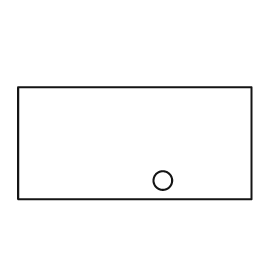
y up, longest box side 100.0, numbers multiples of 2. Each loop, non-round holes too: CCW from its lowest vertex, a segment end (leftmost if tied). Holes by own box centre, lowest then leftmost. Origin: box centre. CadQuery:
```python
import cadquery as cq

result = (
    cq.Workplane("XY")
    .moveTo(-50.0, -24.0)
    .lineTo(50.0, -24.0)
    .lineTo(50.0, 24.0)
    .lineTo(-50.0, 24.0)
    .close()
    .moveTo(12.0, -16.0)
    .circle(4.0)
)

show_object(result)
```